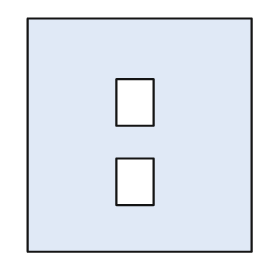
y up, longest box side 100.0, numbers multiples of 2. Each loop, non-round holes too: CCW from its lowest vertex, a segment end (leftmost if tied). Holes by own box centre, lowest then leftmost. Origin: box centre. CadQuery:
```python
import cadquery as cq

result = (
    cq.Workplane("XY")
    .moveTo(-48.0, -50.0)
    .lineTo(48.0, -50.0)
    .lineTo(48.0, 50.0)
    .lineTo(-48.0, 50.0)
    .close()
    .moveTo(-10.0, -30.0)
    .lineTo(6.0, -30.0)
    .lineTo(6.0, -10.0)
    .lineTo(-10.0, -10.0)
    .close()
    .moveTo(-10.0, 4.0)
    .lineTo(6.0, 4.0)
    .lineTo(6.0, 24.0)
    .lineTo(-10.0, 24.0)
    .close()
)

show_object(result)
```